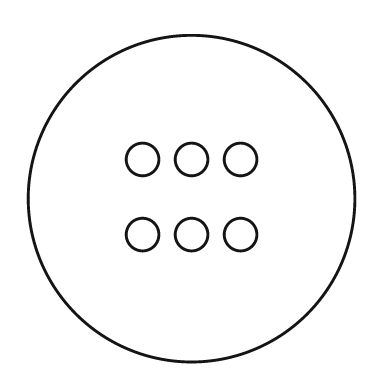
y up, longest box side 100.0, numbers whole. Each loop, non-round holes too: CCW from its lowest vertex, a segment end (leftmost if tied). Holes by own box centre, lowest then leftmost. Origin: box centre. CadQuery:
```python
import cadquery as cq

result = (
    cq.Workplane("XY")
    .moveTo(0.0, 0.0)
    .circle(50.0)
    .moveTo(-15.0, -11.0)
    .circle(5.0)
    .moveTo(0.0, -11.0)
    .circle(5.0)
    .moveTo(15.0, -11.0)
    .circle(5.0)
    .moveTo(-15.0, 12.0)
    .circle(5.0)
    .moveTo(0.0, 12.0)
    .circle(5.0)
    .moveTo(15.0, 12.0)
    .circle(5.0)
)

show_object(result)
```